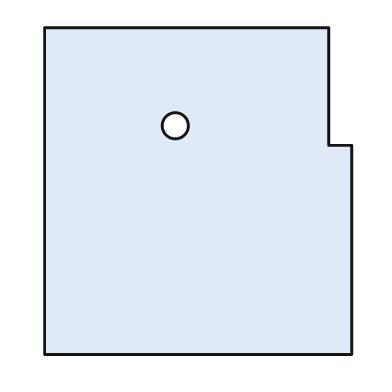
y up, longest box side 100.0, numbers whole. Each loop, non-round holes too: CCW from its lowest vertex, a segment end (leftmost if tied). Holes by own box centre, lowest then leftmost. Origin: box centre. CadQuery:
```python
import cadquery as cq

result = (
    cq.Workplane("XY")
    .moveTo(-47.0, -50.0)
    .lineTo(47.0, -50.0)
    .lineTo(47.0, 14.0)
    .lineTo(40.0, 14.0)
    .lineTo(40.0, 50.0)
    .lineTo(-47.0, 50.0)
    .close()
    .moveTo(-7.0, 20.0)
    .circle(4.0)
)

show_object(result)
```